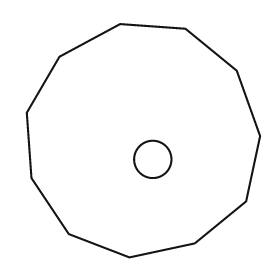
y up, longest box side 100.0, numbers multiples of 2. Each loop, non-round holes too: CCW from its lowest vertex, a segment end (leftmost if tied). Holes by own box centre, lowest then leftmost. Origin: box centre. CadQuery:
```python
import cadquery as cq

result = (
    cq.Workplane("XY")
    .moveTo(-6.0, -50.0)
    .lineTo(22.0, -44.0)
    .lineTo(44.0, -26.0)
    .lineTo(50.0, 2.0)
    .lineTo(40.0, 30.0)
    .lineTo(18.0, 48.0)
    .lineTo(-10.0, 50.0)
    .lineTo(-36.0, 36.0)
    .lineTo(-50.0, 12.0)
    .lineTo(-48.0, -16.0)
    .lineTo(-32.0, -40.0)
    .close()
    .moveTo(4.0, -8.0)
    .circle(8.0)
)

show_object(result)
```